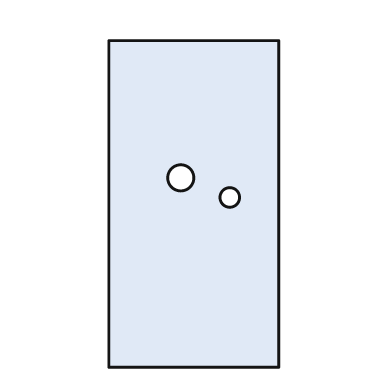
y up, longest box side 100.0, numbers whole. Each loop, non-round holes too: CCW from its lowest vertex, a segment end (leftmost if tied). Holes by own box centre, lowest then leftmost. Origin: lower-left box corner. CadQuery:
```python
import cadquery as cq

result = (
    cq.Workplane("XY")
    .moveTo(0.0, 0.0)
    .lineTo(52.0, 0.0)
    .lineTo(52.0, 100.0)
    .lineTo(0.0, 100.0)
    .close()
    .moveTo(37.0, 52.0)
    .circle(3.0)
    .moveTo(22.0, 58.0)
    .circle(4.0)
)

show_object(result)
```